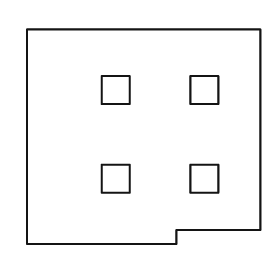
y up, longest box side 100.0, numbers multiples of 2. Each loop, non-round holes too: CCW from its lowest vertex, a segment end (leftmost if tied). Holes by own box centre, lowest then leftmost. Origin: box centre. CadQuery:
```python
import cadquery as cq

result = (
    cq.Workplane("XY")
    .moveTo(-50.0, -46.0)
    .lineTo(14.0, -46.0)
    .lineTo(14.0, -40.0)
    .lineTo(50.0, -40.0)
    .lineTo(50.0, 46.0)
    .lineTo(-50.0, 46.0)
    .close()
    .moveTo(-18.0, -24.0)
    .lineTo(-6.0, -24.0)
    .lineTo(-6.0, -12.0)
    .lineTo(-18.0, -12.0)
    .close()
    .moveTo(20.0, -24.0)
    .lineTo(32.0, -24.0)
    .lineTo(32.0, -12.0)
    .lineTo(20.0, -12.0)
    .close()
    .moveTo(-18.0, 14.0)
    .lineTo(-6.0, 14.0)
    .lineTo(-6.0, 26.0)
    .lineTo(-18.0, 26.0)
    .close()
    .moveTo(20.0, 14.0)
    .lineTo(32.0, 14.0)
    .lineTo(32.0, 26.0)
    .lineTo(20.0, 26.0)
    .close()
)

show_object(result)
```